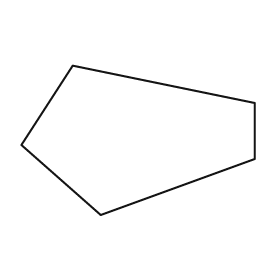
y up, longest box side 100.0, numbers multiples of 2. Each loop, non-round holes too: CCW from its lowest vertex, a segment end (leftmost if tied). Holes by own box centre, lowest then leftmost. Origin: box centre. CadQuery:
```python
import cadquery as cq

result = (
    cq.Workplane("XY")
    .moveTo(-16.0, -32.0)
    .lineTo(50.0, -8.0)
    .lineTo(50.0, 16.0)
    .lineTo(-28.0, 32.0)
    .lineTo(-50.0, -2.0)
    .close()
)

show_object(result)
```